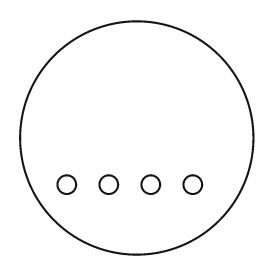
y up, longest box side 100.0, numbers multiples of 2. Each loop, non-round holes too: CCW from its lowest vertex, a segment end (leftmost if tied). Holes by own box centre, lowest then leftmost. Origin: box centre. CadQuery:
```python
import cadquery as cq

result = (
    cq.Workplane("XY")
    .moveTo(0.0, 0.0)
    .circle(50.0)
    .moveTo(-30.0, -20.0)
    .circle(4.0)
    .moveTo(-12.0, -20.0)
    .circle(4.0)
    .moveTo(6.0, -20.0)
    .circle(4.0)
    .moveTo(24.0, -20.0)
    .circle(4.0)
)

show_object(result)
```